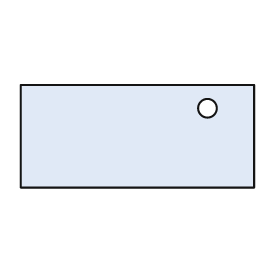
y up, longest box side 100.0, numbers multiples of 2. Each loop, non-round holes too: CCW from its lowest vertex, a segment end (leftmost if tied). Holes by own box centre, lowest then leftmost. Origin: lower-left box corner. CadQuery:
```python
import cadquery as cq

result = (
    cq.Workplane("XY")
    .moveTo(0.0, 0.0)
    .lineTo(100.0, 0.0)
    .lineTo(100.0, 44.0)
    .lineTo(0.0, 44.0)
    .close()
    .moveTo(80.0, 34.0)
    .circle(4.0)
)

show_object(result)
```